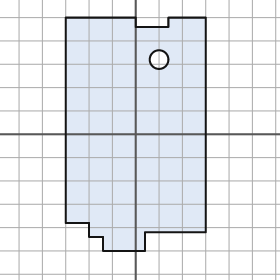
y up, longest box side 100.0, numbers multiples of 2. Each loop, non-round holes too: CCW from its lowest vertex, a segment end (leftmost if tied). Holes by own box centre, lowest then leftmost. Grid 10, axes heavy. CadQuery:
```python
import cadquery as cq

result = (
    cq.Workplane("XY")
    .moveTo(-14.0, -50.0)
    .lineTo(4.0, -50.0)
    .lineTo(4.0, -42.0)
    .lineTo(30.0, -42.0)
    .lineTo(30.0, 50.0)
    .lineTo(14.0, 50.0)
    .lineTo(14.0, 46.0)
    .lineTo(0.0, 46.0)
    .lineTo(0.0, 50.0)
    .lineTo(-30.0, 50.0)
    .lineTo(-30.0, -38.0)
    .lineTo(-20.0, -38.0)
    .lineTo(-20.0, -44.0)
    .lineTo(-14.0, -44.0)
    .close()
    .moveTo(10.0, 32.0)
    .circle(4.0)
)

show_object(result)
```